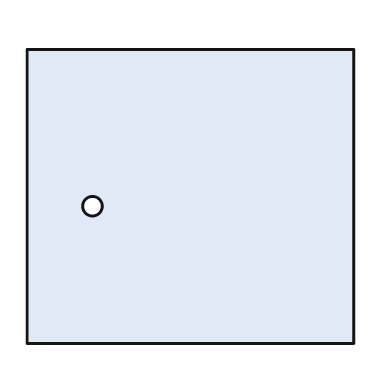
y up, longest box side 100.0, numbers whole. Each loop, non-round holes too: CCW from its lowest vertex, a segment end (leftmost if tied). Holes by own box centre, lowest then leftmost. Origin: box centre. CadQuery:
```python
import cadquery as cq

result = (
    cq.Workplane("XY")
    .moveTo(-50.0, -45.0)
    .lineTo(50.0, -45.0)
    .lineTo(50.0, 45.0)
    .lineTo(-50.0, 45.0)
    .close()
    .moveTo(-30.0, -3.0)
    .circle(3.0)
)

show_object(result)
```